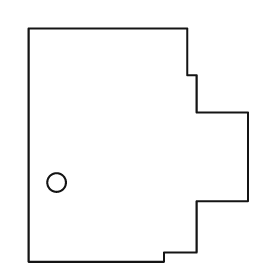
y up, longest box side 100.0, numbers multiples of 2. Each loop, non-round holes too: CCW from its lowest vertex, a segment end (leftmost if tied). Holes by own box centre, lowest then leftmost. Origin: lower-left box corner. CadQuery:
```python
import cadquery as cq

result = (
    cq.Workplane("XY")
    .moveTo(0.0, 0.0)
    .lineTo(58.0, 0.0)
    .lineTo(58.0, 4.0)
    .lineTo(72.0, 4.0)
    .lineTo(72.0, 26.0)
    .lineTo(94.0, 26.0)
    .lineTo(94.0, 64.0)
    .lineTo(72.0, 64.0)
    .lineTo(72.0, 80.0)
    .lineTo(68.0, 80.0)
    .lineTo(68.0, 100.0)
    .lineTo(0.0, 100.0)
    .close()
    .moveTo(12.0, 34.0)
    .circle(4.0)
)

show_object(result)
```